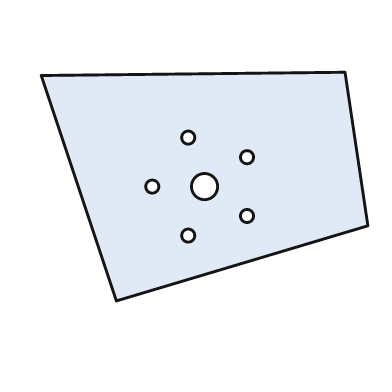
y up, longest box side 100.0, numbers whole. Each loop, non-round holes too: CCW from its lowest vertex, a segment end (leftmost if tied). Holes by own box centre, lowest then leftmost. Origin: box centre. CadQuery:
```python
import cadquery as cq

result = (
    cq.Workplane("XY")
    .moveTo(-27.0, -35.0)
    .lineTo(50.0, -12.0)
    .lineTo(43.0, 35.0)
    .lineTo(-50.0, 34.0)
    .close()
    .moveTo(-5.0, -15.0)
    .circle(2.0)
    .moveTo(13.0, -9.0)
    .circle(2.0)
    .moveTo(-16.0, 0.0)
    .circle(2.0)
    .moveTo(0.0, 0.0)
    .circle(4.0)
    .moveTo(13.0, 9.0)
    .circle(2.0)
    .moveTo(-5.0, 15.0)
    .circle(2.0)
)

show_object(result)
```